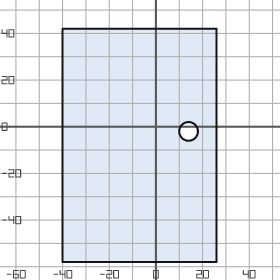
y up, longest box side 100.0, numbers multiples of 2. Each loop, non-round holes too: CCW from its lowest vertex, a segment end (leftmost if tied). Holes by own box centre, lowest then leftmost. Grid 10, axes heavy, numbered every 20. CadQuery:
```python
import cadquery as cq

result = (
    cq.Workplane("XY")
    .moveTo(-40.0, -58.0)
    .lineTo(26.0, -58.0)
    .lineTo(26.0, 42.0)
    .lineTo(-40.0, 42.0)
    .close()
    .moveTo(14.0, -2.0)
    .circle(4.0)
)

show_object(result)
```